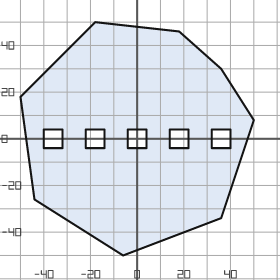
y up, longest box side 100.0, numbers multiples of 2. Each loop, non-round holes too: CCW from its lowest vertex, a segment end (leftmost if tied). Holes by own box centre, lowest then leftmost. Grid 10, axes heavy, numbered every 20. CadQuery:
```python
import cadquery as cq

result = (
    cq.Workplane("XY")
    .moveTo(-6.0, -50.0)
    .lineTo(36.0, -34.0)
    .lineTo(50.0, 8.0)
    .lineTo(36.0, 30.0)
    .lineTo(18.0, 46.0)
    .lineTo(-18.0, 50.0)
    .lineTo(-50.0, 18.0)
    .lineTo(-44.0, -26.0)
    .close()
    .moveTo(-40.0, -4.0)
    .lineTo(-32.0, -4.0)
    .lineTo(-32.0, 4.0)
    .lineTo(-40.0, 4.0)
    .close()
    .moveTo(-22.0, -4.0)
    .lineTo(-14.0, -4.0)
    .lineTo(-14.0, 4.0)
    .lineTo(-22.0, 4.0)
    .close()
    .moveTo(-4.0, -4.0)
    .lineTo(4.0, -4.0)
    .lineTo(4.0, 4.0)
    .lineTo(-4.0, 4.0)
    .close()
    .moveTo(14.0, -4.0)
    .lineTo(22.0, -4.0)
    .lineTo(22.0, 4.0)
    .lineTo(14.0, 4.0)
    .close()
    .moveTo(32.0, -4.0)
    .lineTo(40.0, -4.0)
    .lineTo(40.0, 4.0)
    .lineTo(32.0, 4.0)
    .close()
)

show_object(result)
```